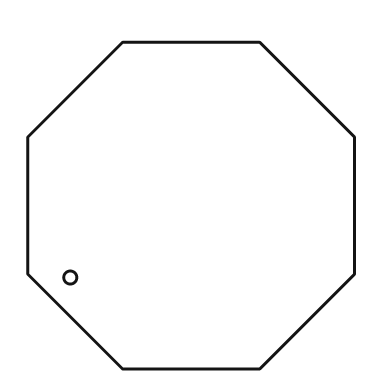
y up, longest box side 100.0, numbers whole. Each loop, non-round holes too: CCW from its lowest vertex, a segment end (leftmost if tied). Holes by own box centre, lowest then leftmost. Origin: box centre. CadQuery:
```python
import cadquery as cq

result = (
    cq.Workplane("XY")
    .moveTo(-21.0, -50.0)
    .lineTo(21.0, -50.0)
    .lineTo(50.0, -21.0)
    .lineTo(50.0, 21.0)
    .lineTo(21.0, 50.0)
    .lineTo(-21.0, 50.0)
    .lineTo(-50.0, 21.0)
    .lineTo(-50.0, -21.0)
    .close()
    .moveTo(-37.0, -22.0)
    .circle(2.0)
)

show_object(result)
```